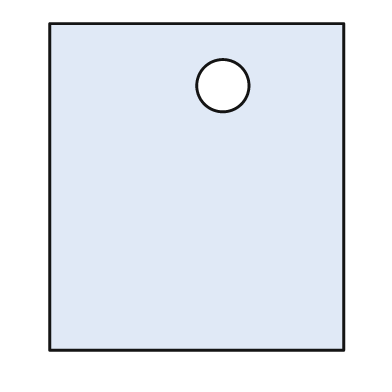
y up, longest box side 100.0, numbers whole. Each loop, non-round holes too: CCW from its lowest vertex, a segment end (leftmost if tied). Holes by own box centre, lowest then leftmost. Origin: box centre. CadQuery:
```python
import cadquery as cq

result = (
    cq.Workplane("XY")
    .moveTo(-45.0, -50.0)
    .lineTo(45.0, -50.0)
    .lineTo(45.0, 50.0)
    .lineTo(-45.0, 50.0)
    .close()
    .moveTo(8.0, 31.0)
    .circle(8.0)
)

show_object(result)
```